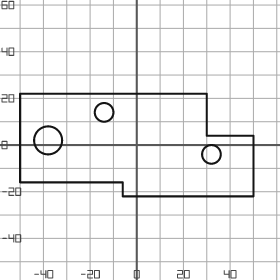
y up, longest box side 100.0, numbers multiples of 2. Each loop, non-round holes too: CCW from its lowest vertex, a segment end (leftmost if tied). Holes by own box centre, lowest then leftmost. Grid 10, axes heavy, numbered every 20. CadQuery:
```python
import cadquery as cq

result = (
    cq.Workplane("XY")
    .moveTo(-6.0, -22.0)
    .lineTo(50.0, -22.0)
    .lineTo(50.0, 4.0)
    .lineTo(30.0, 4.0)
    .lineTo(30.0, 22.0)
    .lineTo(-50.0, 22.0)
    .lineTo(-50.0, -16.0)
    .lineTo(-6.0, -16.0)
    .close()
    .moveTo(32.0, -4.0)
    .circle(4.0)
    .moveTo(-38.0, 2.0)
    .circle(6.0)
    .moveTo(-14.0, 14.0)
    .circle(4.0)
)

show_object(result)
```